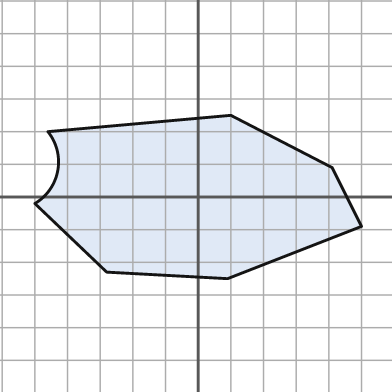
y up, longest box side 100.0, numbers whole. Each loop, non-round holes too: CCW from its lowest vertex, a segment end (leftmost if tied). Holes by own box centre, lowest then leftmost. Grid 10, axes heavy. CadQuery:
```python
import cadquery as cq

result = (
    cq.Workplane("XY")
    .moveTo(9.0, -25.0)
    .lineTo(50.0, -9.0)
    .lineTo(41.0, 9.0)
    .lineTo(10.0, 25.0)
    .lineTo(-46.0, 20.0)
    .threePointArc((-43.0, 8.0), (-50.0, -2.0))
    .lineTo(-28.0, -23.0)
    .close()
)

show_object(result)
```